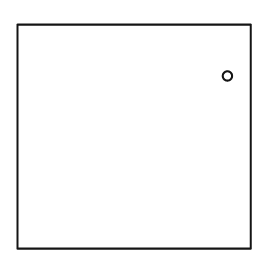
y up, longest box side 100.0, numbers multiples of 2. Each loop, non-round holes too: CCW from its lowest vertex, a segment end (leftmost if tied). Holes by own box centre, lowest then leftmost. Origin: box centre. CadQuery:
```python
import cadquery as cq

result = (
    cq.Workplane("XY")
    .moveTo(-50.0, -48.0)
    .lineTo(50.0, -48.0)
    .lineTo(50.0, 48.0)
    .lineTo(-50.0, 48.0)
    .close()
    .moveTo(40.0, 26.0)
    .circle(2.0)
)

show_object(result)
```